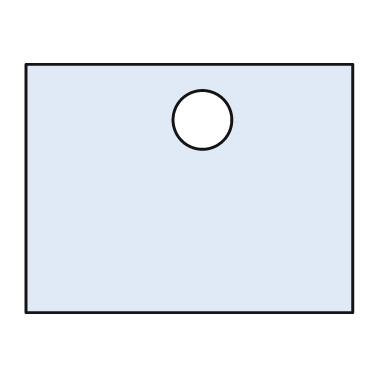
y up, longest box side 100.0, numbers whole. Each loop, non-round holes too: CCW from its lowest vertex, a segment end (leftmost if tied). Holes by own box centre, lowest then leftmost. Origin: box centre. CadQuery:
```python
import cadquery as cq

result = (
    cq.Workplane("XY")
    .moveTo(-50.0, -38.0)
    .lineTo(50.0, -38.0)
    .lineTo(50.0, 38.0)
    .lineTo(-50.0, 38.0)
    .close()
    .moveTo(4.0, 21.0)
    .circle(9.0)
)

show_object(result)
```